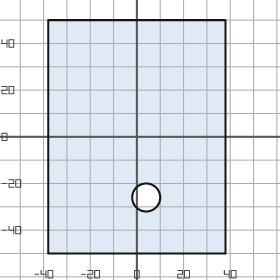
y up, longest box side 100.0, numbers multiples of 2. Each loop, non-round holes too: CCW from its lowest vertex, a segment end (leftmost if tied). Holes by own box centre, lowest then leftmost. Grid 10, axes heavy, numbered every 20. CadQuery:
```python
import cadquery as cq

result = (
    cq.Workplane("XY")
    .moveTo(-38.0, -50.0)
    .lineTo(38.0, -50.0)
    .lineTo(38.0, 50.0)
    .lineTo(-38.0, 50.0)
    .close()
    .moveTo(4.0, -26.0)
    .circle(6.0)
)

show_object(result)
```